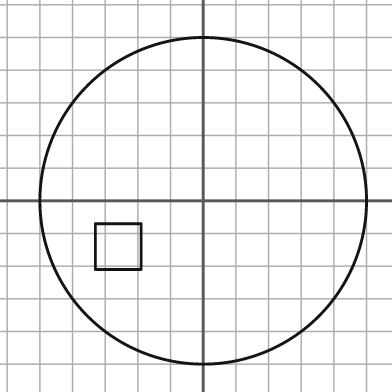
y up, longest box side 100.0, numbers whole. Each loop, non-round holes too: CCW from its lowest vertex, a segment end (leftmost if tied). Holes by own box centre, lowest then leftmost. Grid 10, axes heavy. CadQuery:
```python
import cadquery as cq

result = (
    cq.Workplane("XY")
    .moveTo(0.0, 0.0)
    .circle(50.0)
    .moveTo(-33.0, -21.0)
    .lineTo(-19.0, -21.0)
    .lineTo(-19.0, -7.0)
    .lineTo(-33.0, -7.0)
    .close()
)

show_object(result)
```